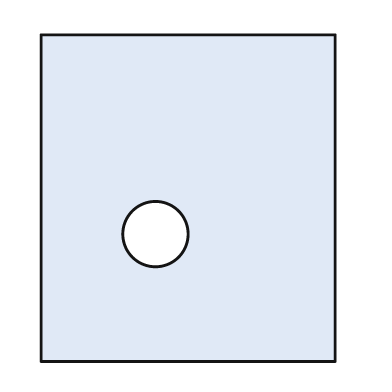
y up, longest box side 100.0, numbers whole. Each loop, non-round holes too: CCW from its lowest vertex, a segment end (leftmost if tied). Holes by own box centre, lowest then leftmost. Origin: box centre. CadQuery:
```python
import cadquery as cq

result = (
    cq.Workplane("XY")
    .moveTo(-45.0, -50.0)
    .lineTo(45.0, -50.0)
    .lineTo(45.0, 50.0)
    .lineTo(-45.0, 50.0)
    .close()
    .moveTo(-10.0, -11.0)
    .circle(10.0)
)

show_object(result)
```